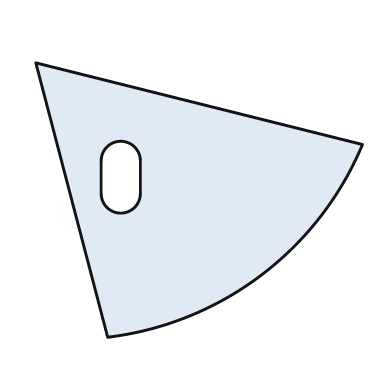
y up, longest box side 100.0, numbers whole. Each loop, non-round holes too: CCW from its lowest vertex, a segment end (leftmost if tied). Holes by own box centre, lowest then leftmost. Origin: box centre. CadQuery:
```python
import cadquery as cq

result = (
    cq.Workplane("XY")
    .moveTo(-28.0, -42.0)
    .threePointArc((19.0, -23.0), (50.0, 17.0))
    .lineTo(-50.0, 42.0)
    .close()
    .moveTo(-30.0, 2.0)
    .threePointArc((-24.0, -4.0), (-18.0, 2.0))
    .lineTo(-18.0, 12.0)
    .threePointArc((-24.0, 18.0), (-30.0, 12.0))
    .close()
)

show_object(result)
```